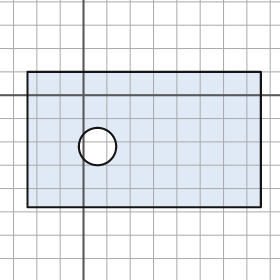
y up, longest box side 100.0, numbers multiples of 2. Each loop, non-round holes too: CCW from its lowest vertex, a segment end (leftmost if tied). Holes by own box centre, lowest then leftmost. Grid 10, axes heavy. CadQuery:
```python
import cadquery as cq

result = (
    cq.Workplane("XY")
    .moveTo(-24.0, -48.0)
    .lineTo(76.0, -48.0)
    .lineTo(76.0, 10.0)
    .lineTo(-24.0, 10.0)
    .close()
    .moveTo(6.0, -22.0)
    .circle(8.0)
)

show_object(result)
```